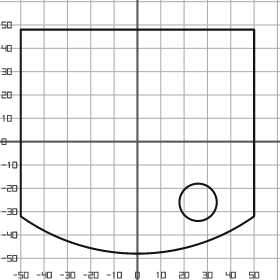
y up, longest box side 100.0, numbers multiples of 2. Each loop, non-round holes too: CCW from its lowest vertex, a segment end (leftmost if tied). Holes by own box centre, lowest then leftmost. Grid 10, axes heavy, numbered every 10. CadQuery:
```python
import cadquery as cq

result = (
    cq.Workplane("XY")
    .moveTo(-50.0, -32.0)
    .threePointArc((0.0, -48.0), (50.0, -32.0))
    .lineTo(50.0, 48.0)
    .lineTo(-50.0, 48.0)
    .close()
    .moveTo(26.0, -26.0)
    .circle(8.0)
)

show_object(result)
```